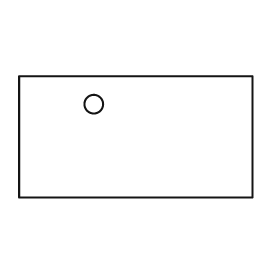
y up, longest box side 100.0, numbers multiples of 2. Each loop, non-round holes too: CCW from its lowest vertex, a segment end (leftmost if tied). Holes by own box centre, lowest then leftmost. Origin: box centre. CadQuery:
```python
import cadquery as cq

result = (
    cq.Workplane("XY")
    .moveTo(-50.0, -26.0)
    .lineTo(50.0, -26.0)
    .lineTo(50.0, 26.0)
    .lineTo(-50.0, 26.0)
    .close()
    .moveTo(-18.0, 14.0)
    .circle(4.0)
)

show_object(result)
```